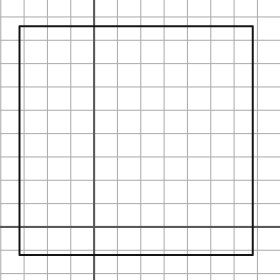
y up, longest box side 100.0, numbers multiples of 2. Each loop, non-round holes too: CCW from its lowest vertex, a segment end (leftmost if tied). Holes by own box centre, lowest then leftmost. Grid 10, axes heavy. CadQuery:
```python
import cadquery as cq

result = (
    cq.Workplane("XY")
    .moveTo(-32.0, -12.0)
    .lineTo(68.0, -12.0)
    .lineTo(68.0, 86.0)
    .lineTo(-32.0, 86.0)
    .close()
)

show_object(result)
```